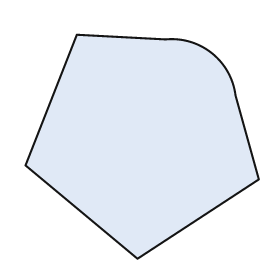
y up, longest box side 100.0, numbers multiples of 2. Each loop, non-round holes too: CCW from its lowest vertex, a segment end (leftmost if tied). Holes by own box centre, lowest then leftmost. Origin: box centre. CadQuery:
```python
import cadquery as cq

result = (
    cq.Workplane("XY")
    .moveTo(-2.0, -48.0)
    .lineTo(50.0, -14.0)
    .lineTo(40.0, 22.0)
    .threePointArc((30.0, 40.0), (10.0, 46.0))
    .lineTo(-28.0, 48.0)
    .lineTo(-50.0, -8.0)
    .close()
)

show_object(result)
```